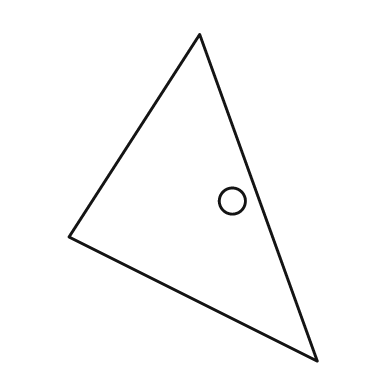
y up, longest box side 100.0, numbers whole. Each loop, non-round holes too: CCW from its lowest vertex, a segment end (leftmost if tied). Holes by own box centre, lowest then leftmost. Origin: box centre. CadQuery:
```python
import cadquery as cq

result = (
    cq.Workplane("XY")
    .moveTo(38.0, -50.0)
    .lineTo(2.0, 50.0)
    .lineTo(-38.0, -12.0)
    .close()
    .moveTo(12.0, -1.0)
    .circle(4.0)
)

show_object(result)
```